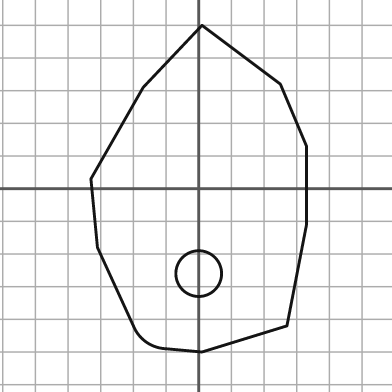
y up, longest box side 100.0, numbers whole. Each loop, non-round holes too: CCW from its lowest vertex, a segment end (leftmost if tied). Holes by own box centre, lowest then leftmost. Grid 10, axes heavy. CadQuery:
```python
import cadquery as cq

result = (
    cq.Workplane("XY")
    .moveTo(1.0, -50.0)
    .lineTo(27.0, -42.0)
    .lineTo(33.0, -11.0)
    .lineTo(33.0, 13.0)
    .lineTo(25.0, 32.0)
    .lineTo(1.0, 50.0)
    .lineTo(-17.0, 31.0)
    .lineTo(-33.0, 3.0)
    .lineTo(-31.0, -18.0)
    .lineTo(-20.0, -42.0)
    .threePointArc((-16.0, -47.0), (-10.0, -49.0))
    .close()
    .moveTo(0.0, -26.0)
    .circle(7.0)
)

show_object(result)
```